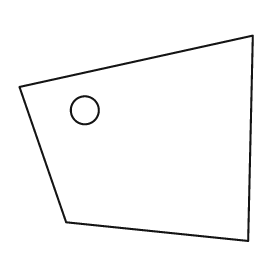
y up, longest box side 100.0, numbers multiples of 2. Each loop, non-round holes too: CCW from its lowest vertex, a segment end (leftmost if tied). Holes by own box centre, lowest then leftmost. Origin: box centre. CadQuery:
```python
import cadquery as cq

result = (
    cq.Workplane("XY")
    .moveTo(48.0, -44.0)
    .lineTo(50.0, 44.0)
    .lineTo(-50.0, 22.0)
    .lineTo(-30.0, -36.0)
    .close()
    .moveTo(-22.0, 12.0)
    .circle(6.0)
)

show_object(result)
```